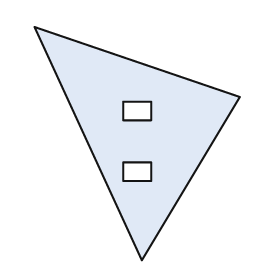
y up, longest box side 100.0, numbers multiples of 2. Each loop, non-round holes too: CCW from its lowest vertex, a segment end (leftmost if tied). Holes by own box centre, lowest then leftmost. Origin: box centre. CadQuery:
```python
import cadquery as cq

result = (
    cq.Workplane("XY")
    .moveTo(2.0, -50.0)
    .lineTo(44.0, 20.0)
    .lineTo(-44.0, 50.0)
    .close()
    .moveTo(-6.0, -16.0)
    .lineTo(6.0, -16.0)
    .lineTo(6.0, -8.0)
    .lineTo(-6.0, -8.0)
    .close()
    .moveTo(-6.0, 10.0)
    .lineTo(6.0, 10.0)
    .lineTo(6.0, 18.0)
    .lineTo(-6.0, 18.0)
    .close()
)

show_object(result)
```